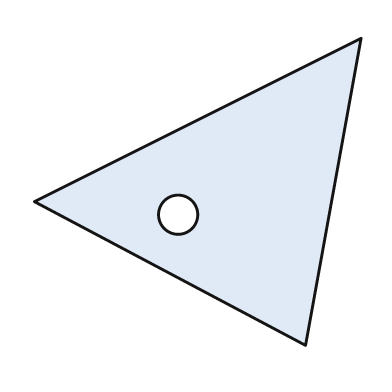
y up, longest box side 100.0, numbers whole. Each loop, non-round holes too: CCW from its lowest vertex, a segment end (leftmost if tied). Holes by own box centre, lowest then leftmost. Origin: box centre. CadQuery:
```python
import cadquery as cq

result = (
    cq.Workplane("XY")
    .moveTo(33.0, -47.0)
    .lineTo(50.0, 47.0)
    .lineTo(-50.0, -3.0)
    .close()
    .moveTo(-6.0, -7.0)
    .circle(6.0)
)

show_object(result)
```